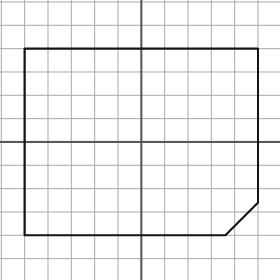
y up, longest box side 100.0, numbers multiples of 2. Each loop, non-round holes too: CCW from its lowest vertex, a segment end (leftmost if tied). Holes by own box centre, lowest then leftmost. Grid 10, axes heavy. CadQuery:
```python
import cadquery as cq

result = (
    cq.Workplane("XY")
    .moveTo(-50.0, -40.0)
    .lineTo(36.0, -40.0)
    .lineTo(50.0, -26.0)
    .lineTo(50.0, 40.0)
    .lineTo(-50.0, 40.0)
    .close()
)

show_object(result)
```